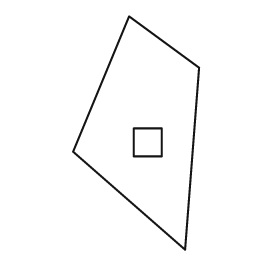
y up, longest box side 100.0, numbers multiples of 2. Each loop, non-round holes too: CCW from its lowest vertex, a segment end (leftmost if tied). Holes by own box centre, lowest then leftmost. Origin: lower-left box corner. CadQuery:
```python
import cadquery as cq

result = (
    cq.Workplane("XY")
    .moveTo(48.0, 0.0)
    .lineTo(54.0, 78.0)
    .lineTo(24.0, 100.0)
    .lineTo(0.0, 42.0)
    .close()
    .moveTo(26.0, 40.0)
    .lineTo(38.0, 40.0)
    .lineTo(38.0, 52.0)
    .lineTo(26.0, 52.0)
    .close()
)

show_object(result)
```